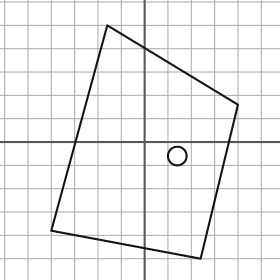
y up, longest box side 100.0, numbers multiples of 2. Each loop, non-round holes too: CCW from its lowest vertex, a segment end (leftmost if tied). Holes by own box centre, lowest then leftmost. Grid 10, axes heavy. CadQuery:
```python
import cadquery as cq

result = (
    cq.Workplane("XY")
    .moveTo(24.0, -50.0)
    .lineTo(40.0, 16.0)
    .lineTo(-16.0, 50.0)
    .lineTo(-40.0, -38.0)
    .close()
    .moveTo(14.0, -6.0)
    .circle(4.0)
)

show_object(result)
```